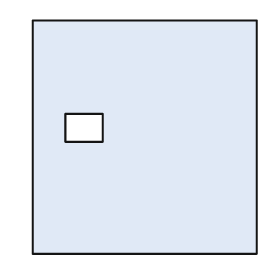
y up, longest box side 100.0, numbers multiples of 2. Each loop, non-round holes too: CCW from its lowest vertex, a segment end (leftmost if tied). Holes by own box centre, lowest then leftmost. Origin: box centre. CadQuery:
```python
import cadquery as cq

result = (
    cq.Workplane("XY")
    .moveTo(-48.0, -50.0)
    .lineTo(48.0, -50.0)
    .lineTo(48.0, 50.0)
    .lineTo(-48.0, 50.0)
    .close()
    .moveTo(-34.0, -2.0)
    .lineTo(-18.0, -2.0)
    .lineTo(-18.0, 10.0)
    .lineTo(-34.0, 10.0)
    .close()
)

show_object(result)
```